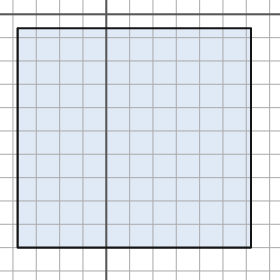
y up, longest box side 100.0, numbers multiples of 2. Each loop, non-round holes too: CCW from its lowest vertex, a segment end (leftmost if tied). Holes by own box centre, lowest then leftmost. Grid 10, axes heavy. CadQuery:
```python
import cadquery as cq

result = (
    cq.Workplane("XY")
    .moveTo(-38.0, -100.0)
    .lineTo(62.0, -100.0)
    .lineTo(62.0, -6.0)
    .lineTo(-38.0, -6.0)
    .close()
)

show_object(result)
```